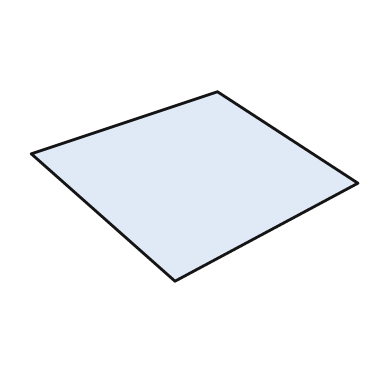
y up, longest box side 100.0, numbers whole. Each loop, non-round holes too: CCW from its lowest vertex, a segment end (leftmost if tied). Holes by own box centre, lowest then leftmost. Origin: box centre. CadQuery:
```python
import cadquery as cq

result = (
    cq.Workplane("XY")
    .moveTo(-6.0, -29.0)
    .lineTo(50.0, 1.0)
    .lineTo(7.0, 29.0)
    .lineTo(-50.0, 10.0)
    .close()
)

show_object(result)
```